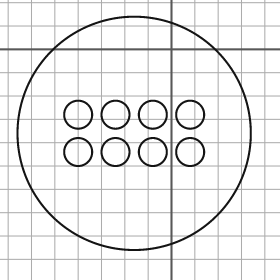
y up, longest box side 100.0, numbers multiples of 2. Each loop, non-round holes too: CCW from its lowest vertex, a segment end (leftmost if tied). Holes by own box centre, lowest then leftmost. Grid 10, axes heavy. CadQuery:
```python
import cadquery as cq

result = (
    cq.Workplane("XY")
    .moveTo(-16.0, -36.0)
    .circle(50.0)
    .moveTo(-40.0, -44.0)
    .circle(6.0)
    .moveTo(-24.0, -44.0)
    .circle(6.0)
    .moveTo(-8.0, -44.0)
    .circle(6.0)
    .moveTo(8.0, -44.0)
    .circle(6.0)
    .moveTo(-40.0, -28.0)
    .circle(6.0)
    .moveTo(-24.0, -28.0)
    .circle(6.0)
    .moveTo(-8.0, -28.0)
    .circle(6.0)
    .moveTo(8.0, -28.0)
    .circle(6.0)
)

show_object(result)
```